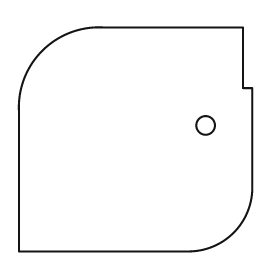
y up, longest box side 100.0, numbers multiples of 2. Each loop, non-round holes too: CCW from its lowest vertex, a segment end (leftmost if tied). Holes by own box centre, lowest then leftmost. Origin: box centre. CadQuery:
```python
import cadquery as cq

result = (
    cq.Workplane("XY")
    .moveTo(-50.0, -48.0)
    .lineTo(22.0, -48.0)
    .threePointArc((42.0, -40.0), (50.0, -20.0))
    .lineTo(50.0, 22.0)
    .lineTo(46.0, 22.0)
    .lineTo(46.0, 48.0)
    .lineTo(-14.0, 48.0)
    .threePointArc((-40.0, 38.0), (-50.0, 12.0))
    .close()
    .moveTo(30.0, 6.0)
    .circle(4.0)
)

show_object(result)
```